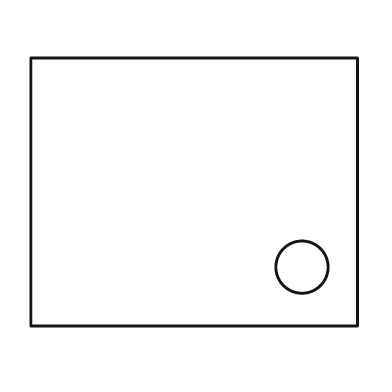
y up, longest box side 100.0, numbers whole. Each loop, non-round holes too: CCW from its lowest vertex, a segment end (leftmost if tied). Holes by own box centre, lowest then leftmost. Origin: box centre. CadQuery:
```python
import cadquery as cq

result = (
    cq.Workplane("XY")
    .moveTo(-50.0, -41.0)
    .lineTo(50.0, -41.0)
    .lineTo(50.0, 41.0)
    .lineTo(-50.0, 41.0)
    .close()
    .moveTo(33.0, -23.0)
    .circle(8.0)
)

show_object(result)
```